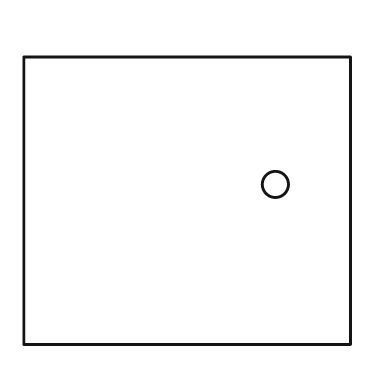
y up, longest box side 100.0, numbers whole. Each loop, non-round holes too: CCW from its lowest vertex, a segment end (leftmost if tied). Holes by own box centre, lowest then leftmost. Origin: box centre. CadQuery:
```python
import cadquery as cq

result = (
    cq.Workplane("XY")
    .moveTo(-50.0, -44.0)
    .lineTo(50.0, -44.0)
    .lineTo(50.0, 44.0)
    .lineTo(-50.0, 44.0)
    .close()
    .moveTo(27.0, 5.0)
    .circle(4.0)
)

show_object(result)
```